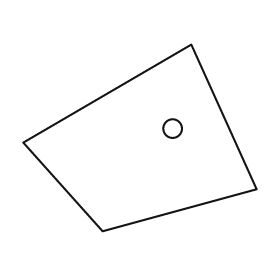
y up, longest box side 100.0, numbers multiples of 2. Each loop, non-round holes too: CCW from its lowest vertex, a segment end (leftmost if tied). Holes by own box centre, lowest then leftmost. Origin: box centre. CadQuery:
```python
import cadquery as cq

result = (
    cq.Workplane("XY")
    .moveTo(-16.0, -40.0)
    .lineTo(50.0, -22.0)
    .lineTo(22.0, 40.0)
    .lineTo(-50.0, -2.0)
    .close()
    .moveTo(14.0, 4.0)
    .circle(4.0)
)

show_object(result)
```